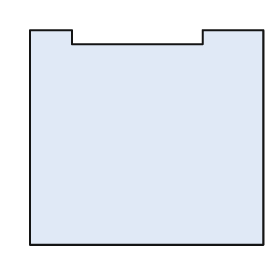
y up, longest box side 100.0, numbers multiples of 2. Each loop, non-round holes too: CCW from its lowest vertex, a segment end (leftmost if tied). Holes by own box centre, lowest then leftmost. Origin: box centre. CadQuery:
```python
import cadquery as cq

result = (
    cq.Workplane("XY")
    .moveTo(-50.0, -46.0)
    .lineTo(50.0, -46.0)
    .lineTo(50.0, 46.0)
    .lineTo(24.0, 46.0)
    .lineTo(24.0, 40.0)
    .lineTo(-32.0, 40.0)
    .lineTo(-32.0, 46.0)
    .lineTo(-50.0, 46.0)
    .close()
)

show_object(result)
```